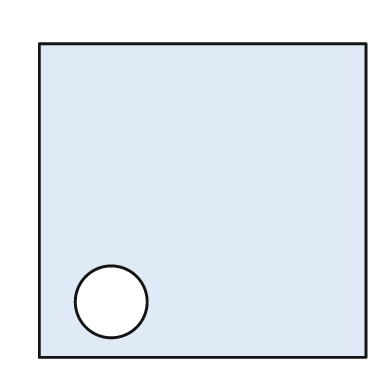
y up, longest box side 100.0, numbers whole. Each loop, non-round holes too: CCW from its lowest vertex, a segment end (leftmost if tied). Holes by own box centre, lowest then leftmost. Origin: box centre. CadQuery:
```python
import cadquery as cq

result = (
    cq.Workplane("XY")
    .moveTo(-50.0, -48.0)
    .lineTo(50.0, -48.0)
    .lineTo(50.0, 48.0)
    .lineTo(-50.0, 48.0)
    .close()
    .moveTo(-28.0, -31.0)
    .circle(11.0)
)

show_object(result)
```